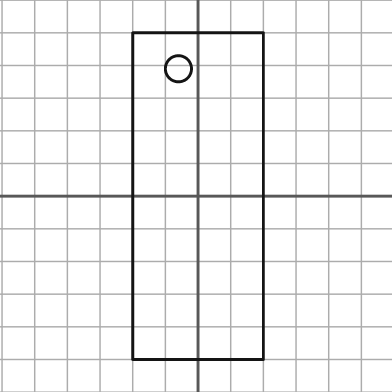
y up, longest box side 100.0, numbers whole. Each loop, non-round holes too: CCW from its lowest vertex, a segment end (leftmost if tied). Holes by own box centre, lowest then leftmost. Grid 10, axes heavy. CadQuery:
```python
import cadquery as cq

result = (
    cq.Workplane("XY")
    .moveTo(-20.0, -50.0)
    .lineTo(20.0, -50.0)
    .lineTo(20.0, 50.0)
    .lineTo(-20.0, 50.0)
    .close()
    .moveTo(-6.0, 39.0)
    .circle(4.0)
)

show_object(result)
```